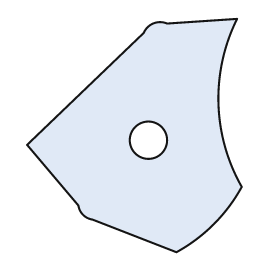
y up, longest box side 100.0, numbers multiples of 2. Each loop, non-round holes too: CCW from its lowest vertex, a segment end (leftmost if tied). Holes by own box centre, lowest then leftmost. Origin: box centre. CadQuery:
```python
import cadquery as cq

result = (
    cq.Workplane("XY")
    .moveTo(18.0, -50.0)
    .threePointArc((34.0, -38.0), (46.0, -22.0))
    .threePointArc((36.0, 14.0), (44.0, 50.0))
    .lineTo(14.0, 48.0)
    .threePointArc((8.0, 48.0), (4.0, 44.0))
    .lineTo(-46.0, -4.0)
    .lineTo(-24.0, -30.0)
    .threePointArc((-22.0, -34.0), (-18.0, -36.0))
    .close()
    .moveTo(6.0, -2.0)
    .circle(8.0)
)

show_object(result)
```